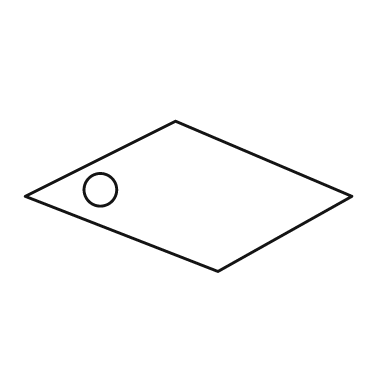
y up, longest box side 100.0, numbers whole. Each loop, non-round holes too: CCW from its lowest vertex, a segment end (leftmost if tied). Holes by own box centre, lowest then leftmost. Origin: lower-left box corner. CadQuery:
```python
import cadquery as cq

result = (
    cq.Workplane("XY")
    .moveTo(59.0, 0.0)
    .lineTo(100.0, 23.0)
    .lineTo(46.0, 46.0)
    .lineTo(0.0, 23.0)
    .close()
    .moveTo(23.0, 25.0)
    .circle(5.0)
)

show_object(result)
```